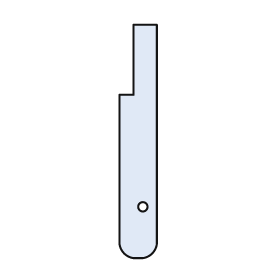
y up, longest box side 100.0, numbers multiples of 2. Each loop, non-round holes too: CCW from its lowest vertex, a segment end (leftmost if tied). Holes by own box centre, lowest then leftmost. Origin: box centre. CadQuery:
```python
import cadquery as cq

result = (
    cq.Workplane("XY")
    .moveTo(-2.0, -50.0)
    .lineTo(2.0, -50.0)
    .threePointArc((6.0, -48.0), (8.0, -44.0))
    .lineTo(8.0, 50.0)
    .lineTo(-2.0, 50.0)
    .lineTo(-2.0, 20.0)
    .lineTo(-8.0, 20.0)
    .lineTo(-8.0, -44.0)
    .threePointArc((-6.0, -48.0), (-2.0, -50.0))
    .close()
    .moveTo(2.0, -28.0)
    .circle(2.0)
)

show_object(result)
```